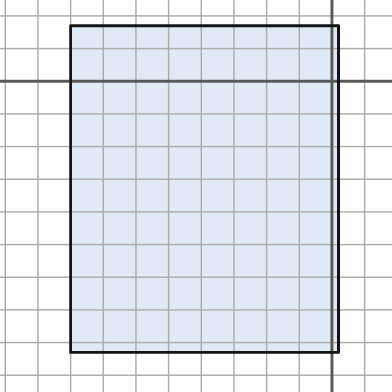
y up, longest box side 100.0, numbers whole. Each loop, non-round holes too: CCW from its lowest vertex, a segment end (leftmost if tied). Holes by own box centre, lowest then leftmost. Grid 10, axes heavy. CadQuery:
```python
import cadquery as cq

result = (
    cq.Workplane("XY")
    .moveTo(-80.0, -83.0)
    .lineTo(2.0, -83.0)
    .lineTo(2.0, 17.0)
    .lineTo(-80.0, 17.0)
    .close()
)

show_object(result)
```